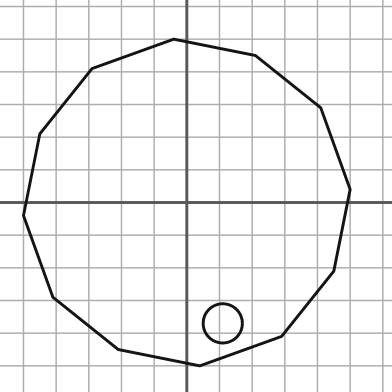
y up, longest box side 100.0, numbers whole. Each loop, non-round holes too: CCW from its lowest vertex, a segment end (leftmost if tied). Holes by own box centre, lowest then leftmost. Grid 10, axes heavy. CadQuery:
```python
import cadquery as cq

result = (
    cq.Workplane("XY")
    .moveTo(4.0, -50.0)
    .lineTo(29.0, -41.0)
    .lineTo(45.0, -21.0)
    .lineTo(50.0, 4.0)
    .lineTo(41.0, 29.0)
    .lineTo(21.0, 45.0)
    .lineTo(-4.0, 50.0)
    .lineTo(-29.0, 41.0)
    .lineTo(-45.0, 21.0)
    .lineTo(-50.0, -4.0)
    .lineTo(-41.0, -29.0)
    .lineTo(-21.0, -45.0)
    .close()
    .moveTo(11.0, -37.0)
    .circle(6.0)
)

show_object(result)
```